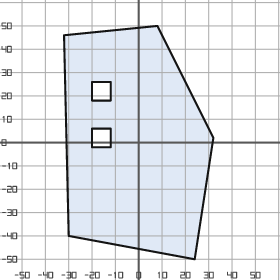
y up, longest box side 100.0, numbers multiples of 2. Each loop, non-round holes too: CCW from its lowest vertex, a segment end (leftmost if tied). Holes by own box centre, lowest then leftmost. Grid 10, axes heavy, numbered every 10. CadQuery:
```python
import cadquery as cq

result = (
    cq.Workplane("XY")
    .moveTo(24.0, -50.0)
    .lineTo(32.0, 2.0)
    .lineTo(8.0, 50.0)
    .lineTo(-32.0, 46.0)
    .lineTo(-30.0, -40.0)
    .close()
    .moveTo(-20.0, -2.0)
    .lineTo(-12.0, -2.0)
    .lineTo(-12.0, 6.0)
    .lineTo(-20.0, 6.0)
    .close()
    .moveTo(-20.0, 18.0)
    .lineTo(-12.0, 18.0)
    .lineTo(-12.0, 26.0)
    .lineTo(-20.0, 26.0)
    .close()
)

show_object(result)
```